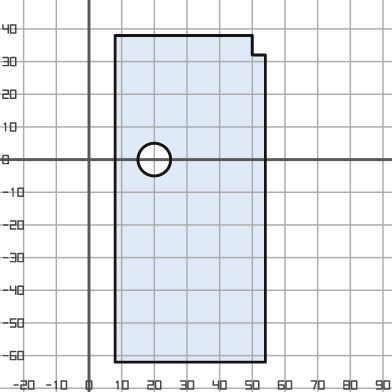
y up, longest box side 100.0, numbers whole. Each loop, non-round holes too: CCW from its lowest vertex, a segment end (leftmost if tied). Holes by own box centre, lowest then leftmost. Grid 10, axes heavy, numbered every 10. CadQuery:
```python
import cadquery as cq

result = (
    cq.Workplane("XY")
    .moveTo(8.0, -62.0)
    .lineTo(54.0, -62.0)
    .lineTo(54.0, 32.0)
    .lineTo(50.0, 32.0)
    .lineTo(50.0, 38.0)
    .lineTo(8.0, 38.0)
    .close()
    .moveTo(20.0, 0.0)
    .circle(5.0)
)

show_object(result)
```